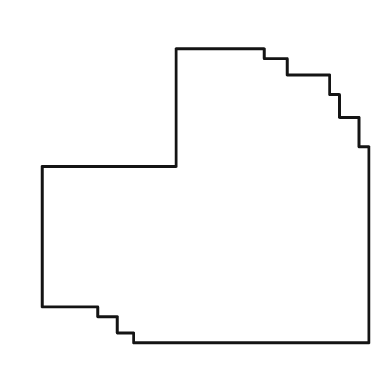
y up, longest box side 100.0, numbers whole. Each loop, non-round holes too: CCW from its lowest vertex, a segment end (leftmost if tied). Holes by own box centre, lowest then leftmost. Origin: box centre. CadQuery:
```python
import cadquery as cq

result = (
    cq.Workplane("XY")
    .moveTo(-22.0, -45.0)
    .lineTo(50.0, -45.0)
    .lineTo(50.0, 15.0)
    .lineTo(47.0, 15.0)
    .lineTo(47.0, 24.0)
    .lineTo(41.0, 24.0)
    .lineTo(41.0, 31.0)
    .lineTo(38.0, 31.0)
    .lineTo(38.0, 37.0)
    .lineTo(25.0, 37.0)
    .lineTo(25.0, 42.0)
    .lineTo(18.0, 42.0)
    .lineTo(18.0, 45.0)
    .lineTo(-9.0, 45.0)
    .lineTo(-9.0, 9.0)
    .lineTo(-50.0, 9.0)
    .lineTo(-50.0, -34.0)
    .lineTo(-33.0, -34.0)
    .lineTo(-33.0, -37.0)
    .lineTo(-27.0, -37.0)
    .lineTo(-27.0, -42.0)
    .lineTo(-22.0, -42.0)
    .close()
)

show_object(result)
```